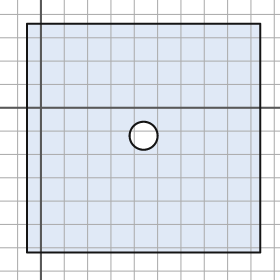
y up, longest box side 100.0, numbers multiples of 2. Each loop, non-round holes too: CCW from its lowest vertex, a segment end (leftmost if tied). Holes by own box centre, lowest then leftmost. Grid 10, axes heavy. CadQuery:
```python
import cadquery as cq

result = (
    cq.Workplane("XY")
    .moveTo(-6.0, -62.0)
    .lineTo(94.0, -62.0)
    .lineTo(94.0, 36.0)
    .lineTo(-6.0, 36.0)
    .close()
    .moveTo(44.0, -12.0)
    .circle(6.0)
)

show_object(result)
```